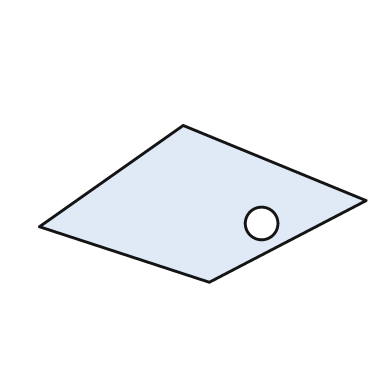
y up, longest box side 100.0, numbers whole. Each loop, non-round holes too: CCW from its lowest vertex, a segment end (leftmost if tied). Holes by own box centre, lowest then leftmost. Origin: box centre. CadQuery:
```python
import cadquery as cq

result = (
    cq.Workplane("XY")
    .moveTo(2.0, -24.0)
    .lineTo(50.0, 1.0)
    .lineTo(-6.0, 24.0)
    .lineTo(-50.0, -7.0)
    .close()
    .moveTo(18.0, -6.0)
    .circle(5.0)
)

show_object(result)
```